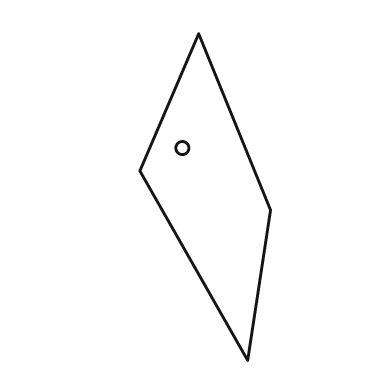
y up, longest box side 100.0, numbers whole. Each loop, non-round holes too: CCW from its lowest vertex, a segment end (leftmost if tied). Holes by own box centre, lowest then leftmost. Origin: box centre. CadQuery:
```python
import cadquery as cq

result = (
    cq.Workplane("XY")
    .moveTo(13.0, -50.0)
    .lineTo(20.0, -4.0)
    .lineTo(-2.0, 50.0)
    .lineTo(-20.0, 8.0)
    .close()
    .moveTo(-7.0, 15.0)
    .circle(2.0)
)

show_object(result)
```